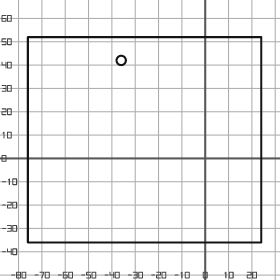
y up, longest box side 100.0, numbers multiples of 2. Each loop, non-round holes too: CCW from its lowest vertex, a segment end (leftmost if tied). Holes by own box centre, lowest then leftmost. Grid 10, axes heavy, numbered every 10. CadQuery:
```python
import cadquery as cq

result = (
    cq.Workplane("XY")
    .moveTo(-76.0, -36.0)
    .lineTo(24.0, -36.0)
    .lineTo(24.0, 52.0)
    .lineTo(-76.0, 52.0)
    .close()
    .moveTo(-36.0, 42.0)
    .circle(2.0)
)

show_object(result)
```